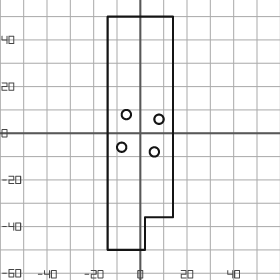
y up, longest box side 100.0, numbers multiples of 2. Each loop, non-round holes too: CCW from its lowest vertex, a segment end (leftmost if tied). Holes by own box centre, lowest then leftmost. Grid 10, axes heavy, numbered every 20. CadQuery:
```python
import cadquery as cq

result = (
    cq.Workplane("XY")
    .moveTo(-14.0, -50.0)
    .lineTo(2.0, -50.0)
    .lineTo(2.0, -36.0)
    .lineTo(14.0, -36.0)
    .lineTo(14.0, 50.0)
    .lineTo(-14.0, 50.0)
    .close()
    .moveTo(6.0, -8.0)
    .circle(2.0)
    .moveTo(-8.0, -6.0)
    .circle(2.0)
    .moveTo(8.0, 6.0)
    .circle(2.0)
    .moveTo(-6.0, 8.0)
    .circle(2.0)
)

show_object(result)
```